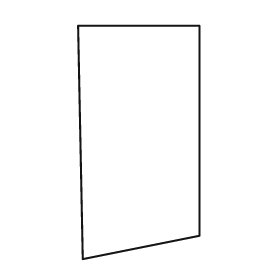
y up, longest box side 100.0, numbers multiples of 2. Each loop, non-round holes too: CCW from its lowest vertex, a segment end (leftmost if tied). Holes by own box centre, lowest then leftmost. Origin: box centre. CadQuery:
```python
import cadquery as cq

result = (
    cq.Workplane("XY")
    .moveTo(-24.0, -50.0)
    .lineTo(26.0, -40.0)
    .lineTo(26.0, 50.0)
    .lineTo(-26.0, 50.0)
    .close()
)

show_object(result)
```